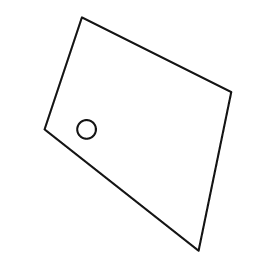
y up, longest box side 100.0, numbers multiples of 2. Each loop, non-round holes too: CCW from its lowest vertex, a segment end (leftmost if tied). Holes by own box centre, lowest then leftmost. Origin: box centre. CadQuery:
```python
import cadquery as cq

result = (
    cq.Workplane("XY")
    .moveTo(26.0, -50.0)
    .lineTo(40.0, 18.0)
    .lineTo(-24.0, 50.0)
    .lineTo(-40.0, 2.0)
    .close()
    .moveTo(-22.0, 2.0)
    .circle(4.0)
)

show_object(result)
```